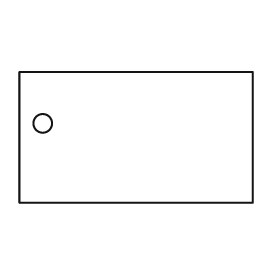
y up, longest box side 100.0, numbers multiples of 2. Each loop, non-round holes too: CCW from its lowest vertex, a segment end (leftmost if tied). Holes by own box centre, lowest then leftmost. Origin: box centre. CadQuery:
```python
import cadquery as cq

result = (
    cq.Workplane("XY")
    .moveTo(-50.0, -28.0)
    .lineTo(50.0, -28.0)
    .lineTo(50.0, 28.0)
    .lineTo(-50.0, 28.0)
    .close()
    .moveTo(-40.0, 6.0)
    .circle(4.0)
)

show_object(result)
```